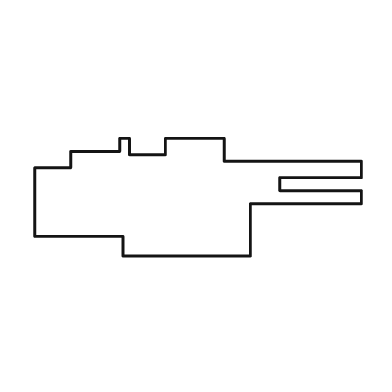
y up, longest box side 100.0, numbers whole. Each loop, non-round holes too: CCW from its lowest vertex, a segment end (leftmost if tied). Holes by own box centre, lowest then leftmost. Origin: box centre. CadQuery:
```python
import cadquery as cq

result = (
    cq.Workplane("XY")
    .moveTo(-23.0, -18.0)
    .lineTo(16.0, -18.0)
    .lineTo(16.0, -2.0)
    .lineTo(50.0, -2.0)
    .lineTo(50.0, 2.0)
    .lineTo(25.0, 2.0)
    .lineTo(25.0, 6.0)
    .lineTo(50.0, 6.0)
    .lineTo(50.0, 11.0)
    .lineTo(8.0, 11.0)
    .lineTo(8.0, 18.0)
    .lineTo(-10.0, 18.0)
    .lineTo(-10.0, 13.0)
    .lineTo(-21.0, 13.0)
    .lineTo(-21.0, 18.0)
    .lineTo(-24.0, 18.0)
    .lineTo(-24.0, 14.0)
    .lineTo(-39.0, 14.0)
    .lineTo(-39.0, 9.0)
    .lineTo(-50.0, 9.0)
    .lineTo(-50.0, -12.0)
    .lineTo(-23.0, -12.0)
    .close()
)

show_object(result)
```